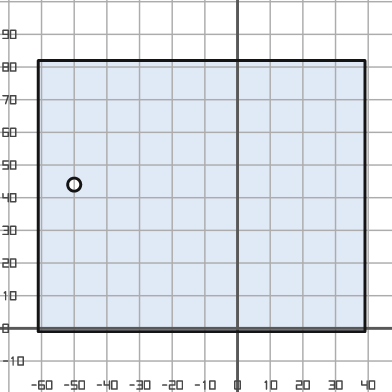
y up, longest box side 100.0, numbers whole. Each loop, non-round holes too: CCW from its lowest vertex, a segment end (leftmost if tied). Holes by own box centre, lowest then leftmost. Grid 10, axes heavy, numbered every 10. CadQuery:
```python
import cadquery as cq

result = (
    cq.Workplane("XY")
    .moveTo(-61.0, -1.0)
    .lineTo(39.0, -1.0)
    .lineTo(39.0, 82.0)
    .lineTo(-61.0, 82.0)
    .close()
    .moveTo(-50.0, 44.0)
    .circle(2.0)
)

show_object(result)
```